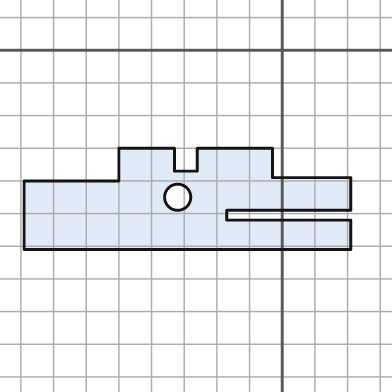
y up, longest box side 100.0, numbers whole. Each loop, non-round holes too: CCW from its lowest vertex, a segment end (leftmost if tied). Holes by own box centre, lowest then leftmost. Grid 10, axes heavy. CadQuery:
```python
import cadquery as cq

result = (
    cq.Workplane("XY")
    .moveTo(-79.0, -61.0)
    .lineTo(21.0, -61.0)
    .lineTo(21.0, -52.0)
    .lineTo(-17.0, -52.0)
    .lineTo(-17.0, -49.0)
    .lineTo(21.0, -49.0)
    .lineTo(21.0, -39.0)
    .lineTo(-3.0, -39.0)
    .lineTo(-3.0, -30.0)
    .lineTo(-26.0, -30.0)
    .lineTo(-26.0, -37.0)
    .lineTo(-33.0, -37.0)
    .lineTo(-33.0, -30.0)
    .lineTo(-50.0, -30.0)
    .lineTo(-50.0, -40.0)
    .lineTo(-79.0, -40.0)
    .close()
    .moveTo(-32.0, -45.0)
    .circle(4.0)
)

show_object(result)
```